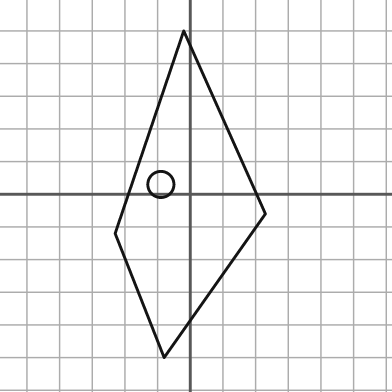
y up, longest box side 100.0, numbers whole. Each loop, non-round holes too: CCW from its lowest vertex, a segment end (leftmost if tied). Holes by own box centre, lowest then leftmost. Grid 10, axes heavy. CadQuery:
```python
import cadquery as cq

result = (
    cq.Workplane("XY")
    .moveTo(-8.0, -50.0)
    .lineTo(23.0, -6.0)
    .lineTo(-2.0, 50.0)
    .lineTo(-23.0, -12.0)
    .close()
    .moveTo(-9.0, 3.0)
    .circle(4.0)
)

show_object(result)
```